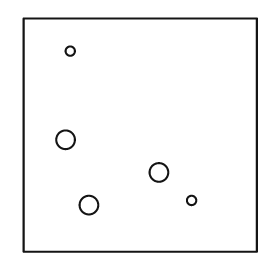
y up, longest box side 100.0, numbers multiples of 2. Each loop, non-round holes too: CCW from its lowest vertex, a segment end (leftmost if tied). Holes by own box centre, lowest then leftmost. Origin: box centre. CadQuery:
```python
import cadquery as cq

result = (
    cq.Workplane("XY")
    .moveTo(-50.0, -50.0)
    .lineTo(50.0, -50.0)
    .lineTo(50.0, 50.0)
    .lineTo(-50.0, 50.0)
    .close()
    .moveTo(-22.0, -30.0)
    .circle(4.0)
    .moveTo(22.0, -28.0)
    .circle(2.0)
    .moveTo(8.0, -16.0)
    .circle(4.0)
    .moveTo(-32.0, -2.0)
    .circle(4.0)
    .moveTo(-30.0, 36.0)
    .circle(2.0)
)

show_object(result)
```